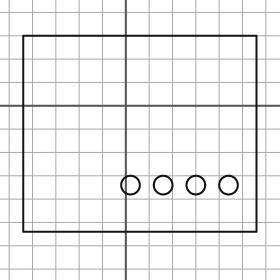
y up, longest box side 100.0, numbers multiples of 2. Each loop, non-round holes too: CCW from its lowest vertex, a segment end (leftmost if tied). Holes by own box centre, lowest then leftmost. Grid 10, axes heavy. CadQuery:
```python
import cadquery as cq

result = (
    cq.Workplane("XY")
    .moveTo(-44.0, -54.0)
    .lineTo(56.0, -54.0)
    .lineTo(56.0, 30.0)
    .lineTo(-44.0, 30.0)
    .close()
    .moveTo(2.0, -34.0)
    .circle(4.0)
    .moveTo(16.0, -34.0)
    .circle(4.0)
    .moveTo(30.0, -34.0)
    .circle(4.0)
    .moveTo(44.0, -34.0)
    .circle(4.0)
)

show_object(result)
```